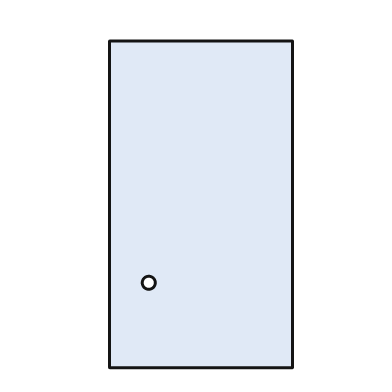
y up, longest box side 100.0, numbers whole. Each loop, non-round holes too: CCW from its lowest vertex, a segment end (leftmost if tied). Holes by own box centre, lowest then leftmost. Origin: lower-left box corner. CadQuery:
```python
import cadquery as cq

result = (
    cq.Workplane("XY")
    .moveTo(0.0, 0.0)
    .lineTo(56.0, 0.0)
    .lineTo(56.0, 100.0)
    .lineTo(0.0, 100.0)
    .close()
    .moveTo(12.0, 26.0)
    .circle(2.0)
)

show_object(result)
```